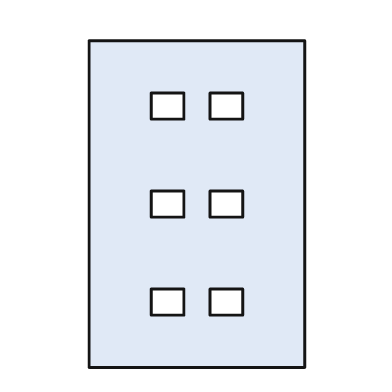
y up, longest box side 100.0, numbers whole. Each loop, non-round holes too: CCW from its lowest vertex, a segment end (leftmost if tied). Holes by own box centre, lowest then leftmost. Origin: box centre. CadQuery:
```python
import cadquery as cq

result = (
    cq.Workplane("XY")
    .moveTo(-33.0, -50.0)
    .lineTo(33.0, -50.0)
    .lineTo(33.0, 50.0)
    .lineTo(-33.0, 50.0)
    .close()
    .moveTo(-14.0, -34.0)
    .lineTo(-4.0, -34.0)
    .lineTo(-4.0, -26.0)
    .lineTo(-14.0, -26.0)
    .close()
    .moveTo(4.0, -34.0)
    .lineTo(14.0, -34.0)
    .lineTo(14.0, -26.0)
    .lineTo(4.0, -26.0)
    .close()
    .moveTo(-14.0, -4.0)
    .lineTo(-4.0, -4.0)
    .lineTo(-4.0, 4.0)
    .lineTo(-14.0, 4.0)
    .close()
    .moveTo(4.0, -4.0)
    .lineTo(14.0, -4.0)
    .lineTo(14.0, 4.0)
    .lineTo(4.0, 4.0)
    .close()
    .moveTo(-14.0, 26.0)
    .lineTo(-4.0, 26.0)
    .lineTo(-4.0, 34.0)
    .lineTo(-14.0, 34.0)
    .close()
    .moveTo(4.0, 26.0)
    .lineTo(14.0, 26.0)
    .lineTo(14.0, 34.0)
    .lineTo(4.0, 34.0)
    .close()
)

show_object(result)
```